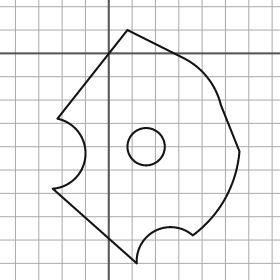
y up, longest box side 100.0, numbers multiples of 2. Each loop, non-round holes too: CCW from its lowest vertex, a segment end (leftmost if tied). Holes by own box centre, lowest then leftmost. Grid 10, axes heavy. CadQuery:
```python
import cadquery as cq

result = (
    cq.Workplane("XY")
    .moveTo(12.0, -90.0)
    .threePointArc((20.0, -76.0), (36.0, -78.0))
    .threePointArc((50.0, -62.0), (56.0, -42.0))
    .lineTo(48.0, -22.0)
    .threePointArc((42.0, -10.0), (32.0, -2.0))
    .lineTo(8.0, 10.0)
    .lineTo(-22.0, -28.0)
    .threePointArc((-10.0, -44.0), (-24.0, -58.0))
    .close()
    .moveTo(16.0, -40.0)
    .circle(8.0)
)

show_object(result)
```